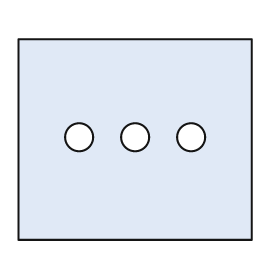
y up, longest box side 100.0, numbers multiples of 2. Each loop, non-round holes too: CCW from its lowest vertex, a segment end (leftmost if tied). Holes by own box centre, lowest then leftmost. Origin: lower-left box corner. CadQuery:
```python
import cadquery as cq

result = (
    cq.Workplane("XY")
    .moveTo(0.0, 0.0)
    .lineTo(100.0, 0.0)
    .lineTo(100.0, 86.0)
    .lineTo(0.0, 86.0)
    .close()
    .moveTo(26.0, 44.0)
    .circle(6.0)
    .moveTo(50.0, 44.0)
    .circle(6.0)
    .moveTo(74.0, 44.0)
    .circle(6.0)
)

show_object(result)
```